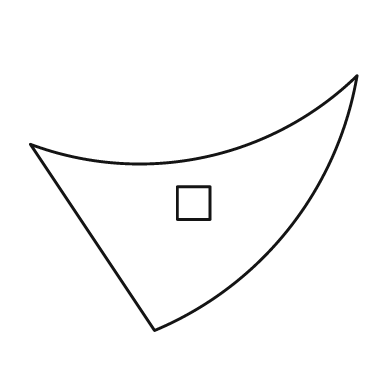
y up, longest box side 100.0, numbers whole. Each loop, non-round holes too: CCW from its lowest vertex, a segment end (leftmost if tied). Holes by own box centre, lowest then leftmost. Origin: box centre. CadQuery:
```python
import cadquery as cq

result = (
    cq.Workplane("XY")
    .moveTo(-12.0, -39.0)
    .threePointArc((29.0, -8.0), (50.0, 39.0))
    .threePointArc((3.0, 14.0), (-50.0, 18.0))
    .close()
    .moveTo(-5.0, -5.0)
    .lineTo(5.0, -5.0)
    .lineTo(5.0, 5.0)
    .lineTo(-5.0, 5.0)
    .close()
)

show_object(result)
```